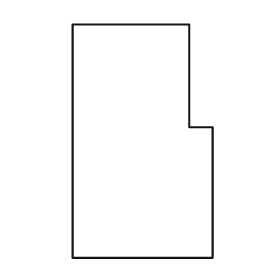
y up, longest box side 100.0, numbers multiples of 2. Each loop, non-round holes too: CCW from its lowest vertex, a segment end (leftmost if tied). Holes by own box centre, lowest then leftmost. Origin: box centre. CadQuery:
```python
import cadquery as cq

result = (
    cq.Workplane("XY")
    .moveTo(-30.0, -50.0)
    .lineTo(30.0, -50.0)
    .lineTo(30.0, 6.0)
    .lineTo(20.0, 6.0)
    .lineTo(20.0, 50.0)
    .lineTo(-30.0, 50.0)
    .close()
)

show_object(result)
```